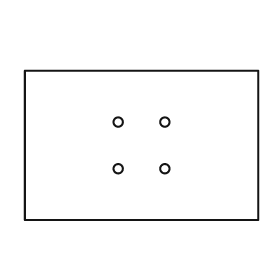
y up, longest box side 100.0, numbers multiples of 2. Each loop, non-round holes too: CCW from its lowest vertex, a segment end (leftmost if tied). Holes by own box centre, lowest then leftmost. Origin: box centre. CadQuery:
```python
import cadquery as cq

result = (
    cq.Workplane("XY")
    .moveTo(-50.0, -32.0)
    .lineTo(50.0, -32.0)
    .lineTo(50.0, 32.0)
    .lineTo(-50.0, 32.0)
    .close()
    .moveTo(-10.0, -10.0)
    .circle(2.0)
    .moveTo(10.0, -10.0)
    .circle(2.0)
    .moveTo(-10.0, 10.0)
    .circle(2.0)
    .moveTo(10.0, 10.0)
    .circle(2.0)
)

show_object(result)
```